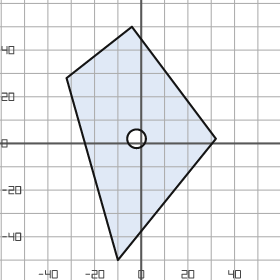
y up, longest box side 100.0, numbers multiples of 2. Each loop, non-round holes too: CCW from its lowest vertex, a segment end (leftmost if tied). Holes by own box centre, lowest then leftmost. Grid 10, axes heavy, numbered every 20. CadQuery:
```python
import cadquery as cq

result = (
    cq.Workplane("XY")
    .moveTo(-10.0, -50.0)
    .lineTo(32.0, 2.0)
    .lineTo(-4.0, 50.0)
    .lineTo(-32.0, 28.0)
    .close()
    .moveTo(-2.0, 2.0)
    .circle(4.0)
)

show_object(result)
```